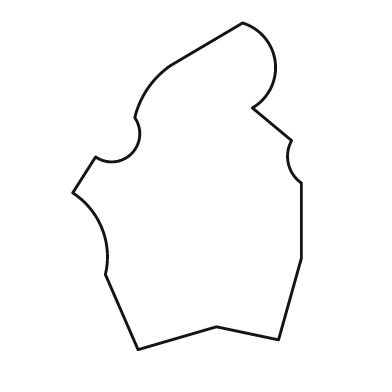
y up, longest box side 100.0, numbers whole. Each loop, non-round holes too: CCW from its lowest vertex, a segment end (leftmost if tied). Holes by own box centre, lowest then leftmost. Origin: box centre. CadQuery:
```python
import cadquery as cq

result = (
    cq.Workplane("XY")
    .moveTo(-15.0, -50.0)
    .lineTo(9.0, -43.0)
    .lineTo(28.0, -47.0)
    .lineTo(35.0, -22.0)
    .lineTo(35.0, 1.0)
    .threePointArc((31.0, 7.0), (32.0, 14.0))
    .lineTo(20.0, 24.0)
    .threePointArc((27.0, 38.0), (17.0, 50.0))
    .lineTo(-5.0, 37.0)
    .threePointArc((-12.0, 30.0), (-16.0, 21.0))
    .threePointArc((-17.0, 10.0), (-28.0, 9.0))
    .lineTo(-35.0, -2.0)
    .threePointArc((-26.0, -13.0), (-25.0, -27.0))
    .close()
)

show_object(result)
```